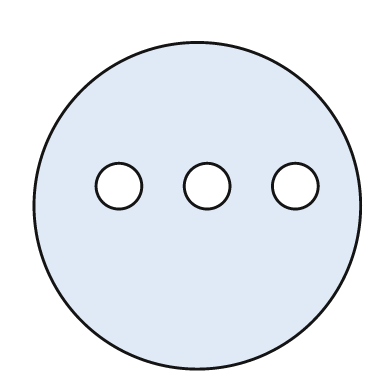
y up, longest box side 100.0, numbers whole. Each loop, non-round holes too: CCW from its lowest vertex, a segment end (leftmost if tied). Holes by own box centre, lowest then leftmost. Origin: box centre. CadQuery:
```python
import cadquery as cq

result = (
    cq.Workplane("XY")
    .moveTo(0.0, 0.0)
    .circle(50.0)
    .moveTo(-24.0, 6.0)
    .circle(7.0)
    .moveTo(3.0, 6.0)
    .circle(7.0)
    .moveTo(30.0, 6.0)
    .circle(7.0)
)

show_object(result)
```